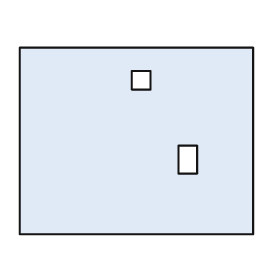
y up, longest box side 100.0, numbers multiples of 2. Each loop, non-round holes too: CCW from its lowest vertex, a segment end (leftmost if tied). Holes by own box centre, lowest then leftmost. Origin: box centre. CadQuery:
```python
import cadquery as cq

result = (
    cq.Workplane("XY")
    .moveTo(-50.0, -40.0)
    .lineTo(50.0, -40.0)
    .lineTo(50.0, 40.0)
    .lineTo(-50.0, 40.0)
    .close()
    .moveTo(18.0, -14.0)
    .lineTo(26.0, -14.0)
    .lineTo(26.0, -2.0)
    .lineTo(18.0, -2.0)
    .close()
    .moveTo(-2.0, 22.0)
    .lineTo(6.0, 22.0)
    .lineTo(6.0, 30.0)
    .lineTo(-2.0, 30.0)
    .close()
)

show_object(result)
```